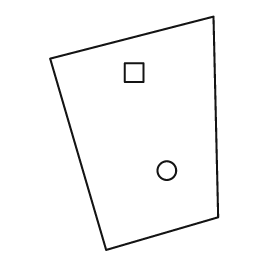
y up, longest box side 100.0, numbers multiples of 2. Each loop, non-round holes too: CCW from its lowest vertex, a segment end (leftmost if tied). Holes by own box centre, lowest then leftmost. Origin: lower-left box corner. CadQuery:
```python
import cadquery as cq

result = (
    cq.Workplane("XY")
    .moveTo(24.0, 0.0)
    .lineTo(72.0, 14.0)
    .lineTo(70.0, 100.0)
    .lineTo(0.0, 82.0)
    .close()
    .moveTo(50.0, 34.0)
    .circle(4.0)
    .moveTo(32.0, 72.0)
    .lineTo(40.0, 72.0)
    .lineTo(40.0, 80.0)
    .lineTo(32.0, 80.0)
    .close()
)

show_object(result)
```